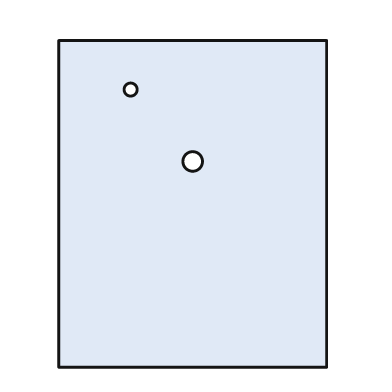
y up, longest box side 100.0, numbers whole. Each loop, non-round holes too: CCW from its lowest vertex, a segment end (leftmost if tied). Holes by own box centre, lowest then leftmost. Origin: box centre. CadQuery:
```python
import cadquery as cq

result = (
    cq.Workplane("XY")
    .moveTo(-41.0, -50.0)
    .lineTo(41.0, -50.0)
    .lineTo(41.0, 50.0)
    .lineTo(-41.0, 50.0)
    .close()
    .moveTo(0.0, 13.0)
    .circle(3.0)
    .moveTo(-19.0, 35.0)
    .circle(2.0)
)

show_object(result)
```